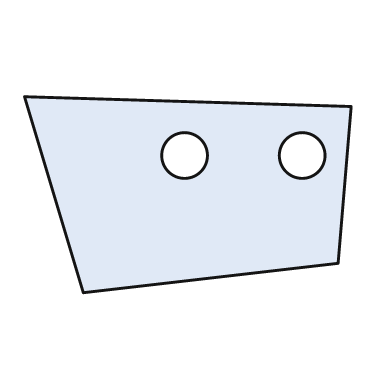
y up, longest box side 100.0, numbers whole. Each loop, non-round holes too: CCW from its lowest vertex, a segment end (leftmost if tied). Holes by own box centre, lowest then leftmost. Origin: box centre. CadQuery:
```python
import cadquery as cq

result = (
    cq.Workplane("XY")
    .moveTo(-32.0, -30.0)
    .lineTo(46.0, -21.0)
    .lineTo(50.0, 27.0)
    .lineTo(-50.0, 30.0)
    .close()
    .moveTo(-1.0, 12.0)
    .circle(7.0)
    .moveTo(35.0, 12.0)
    .circle(7.0)
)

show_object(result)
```